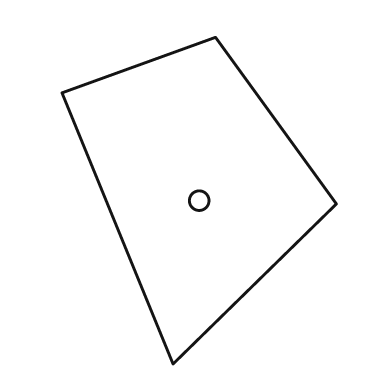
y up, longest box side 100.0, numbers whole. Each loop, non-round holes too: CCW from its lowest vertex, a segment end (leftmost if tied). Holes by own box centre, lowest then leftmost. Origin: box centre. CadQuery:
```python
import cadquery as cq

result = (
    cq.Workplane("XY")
    .moveTo(-8.0, -50.0)
    .lineTo(42.0, -1.0)
    .lineTo(5.0, 50.0)
    .lineTo(-42.0, 33.0)
    .close()
    .moveTo(0.0, 0.0)
    .circle(3.0)
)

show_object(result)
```